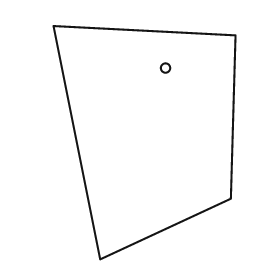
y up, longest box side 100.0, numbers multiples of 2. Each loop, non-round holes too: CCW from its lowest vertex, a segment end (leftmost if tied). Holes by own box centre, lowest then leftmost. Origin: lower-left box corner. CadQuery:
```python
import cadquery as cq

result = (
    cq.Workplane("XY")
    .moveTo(20.0, 0.0)
    .lineTo(76.0, 26.0)
    .lineTo(78.0, 96.0)
    .lineTo(0.0, 100.0)
    .close()
    .moveTo(48.0, 82.0)
    .circle(2.0)
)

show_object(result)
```